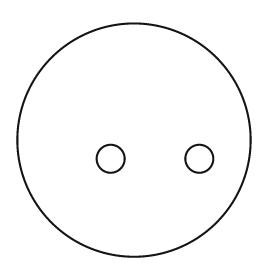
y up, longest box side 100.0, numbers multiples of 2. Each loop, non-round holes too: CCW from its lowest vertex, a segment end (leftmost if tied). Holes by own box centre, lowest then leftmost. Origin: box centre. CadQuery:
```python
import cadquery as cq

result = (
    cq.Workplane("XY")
    .moveTo(0.0, 0.0)
    .circle(50.0)
    .moveTo(-10.0, -8.0)
    .circle(6.0)
    .moveTo(28.0, -8.0)
    .circle(6.0)
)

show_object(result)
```